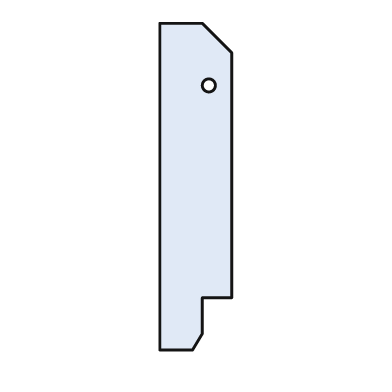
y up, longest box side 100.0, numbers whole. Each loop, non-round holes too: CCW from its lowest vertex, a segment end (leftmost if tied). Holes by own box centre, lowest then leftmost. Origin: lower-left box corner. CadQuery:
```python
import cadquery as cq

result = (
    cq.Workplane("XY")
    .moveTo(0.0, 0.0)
    .lineTo(10.0, 0.0)
    .lineTo(13.0, 5.0)
    .lineTo(13.0, 16.0)
    .lineTo(22.0, 16.0)
    .lineTo(22.0, 91.0)
    .lineTo(13.0, 100.0)
    .lineTo(0.0, 100.0)
    .close()
    .moveTo(15.0, 81.0)
    .circle(2.0)
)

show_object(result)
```